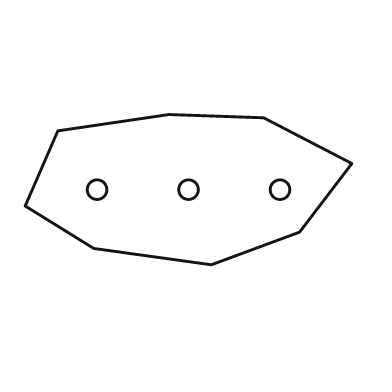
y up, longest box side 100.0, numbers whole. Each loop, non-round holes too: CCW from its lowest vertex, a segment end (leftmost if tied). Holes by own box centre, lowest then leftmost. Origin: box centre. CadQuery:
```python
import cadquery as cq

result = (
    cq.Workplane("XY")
    .moveTo(7.0, -23.0)
    .lineTo(34.0, -13.0)
    .lineTo(50.0, 8.0)
    .lineTo(23.0, 22.0)
    .lineTo(-6.0, 23.0)
    .lineTo(-40.0, 18.0)
    .lineTo(-50.0, -5.0)
    .lineTo(-29.0, -18.0)
    .close()
    .moveTo(-28.0, 0.0)
    .circle(3.0)
    .moveTo(0.0, 0.0)
    .circle(3.0)
    .moveTo(28.0, 0.0)
    .circle(3.0)
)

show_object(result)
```